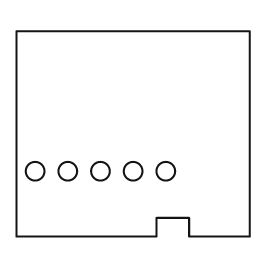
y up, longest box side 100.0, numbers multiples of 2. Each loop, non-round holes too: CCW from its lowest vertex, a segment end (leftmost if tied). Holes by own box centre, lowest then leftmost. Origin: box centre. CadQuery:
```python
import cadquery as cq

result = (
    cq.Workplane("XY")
    .moveTo(-50.0, -44.0)
    .lineTo(10.0, -44.0)
    .lineTo(10.0, -36.0)
    .lineTo(24.0, -36.0)
    .lineTo(24.0, -44.0)
    .lineTo(50.0, -44.0)
    .lineTo(50.0, 44.0)
    .lineTo(-50.0, 44.0)
    .close()
    .moveTo(-42.0, -16.0)
    .circle(4.0)
    .moveTo(-28.0, -16.0)
    .circle(4.0)
    .moveTo(-14.0, -16.0)
    .circle(4.0)
    .moveTo(0.0, -16.0)
    .circle(4.0)
    .moveTo(14.0, -16.0)
    .circle(4.0)
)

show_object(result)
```